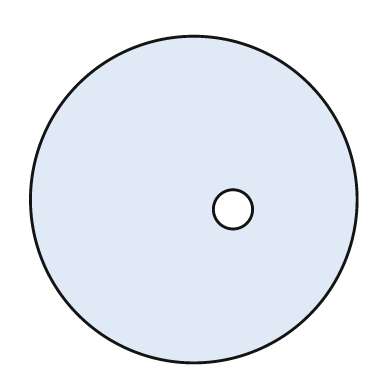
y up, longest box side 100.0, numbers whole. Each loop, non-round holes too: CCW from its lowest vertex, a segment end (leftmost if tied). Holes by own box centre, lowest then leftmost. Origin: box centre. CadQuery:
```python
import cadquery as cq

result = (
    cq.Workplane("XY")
    .moveTo(0.0, 0.0)
    .circle(50.0)
    .moveTo(12.0, -3.0)
    .circle(6.0)
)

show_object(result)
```